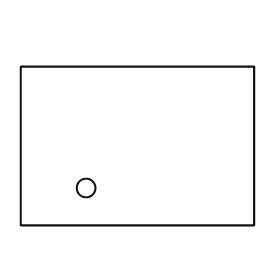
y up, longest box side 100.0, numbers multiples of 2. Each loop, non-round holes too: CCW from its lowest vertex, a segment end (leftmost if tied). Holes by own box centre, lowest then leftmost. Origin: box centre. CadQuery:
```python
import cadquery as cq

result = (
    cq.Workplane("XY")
    .moveTo(-50.0, -34.0)
    .lineTo(50.0, -34.0)
    .lineTo(50.0, 34.0)
    .lineTo(-50.0, 34.0)
    .close()
    .moveTo(-22.0, -18.0)
    .circle(4.0)
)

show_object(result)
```